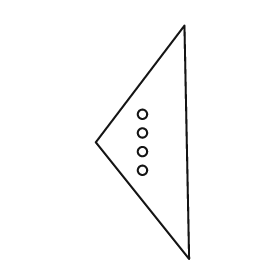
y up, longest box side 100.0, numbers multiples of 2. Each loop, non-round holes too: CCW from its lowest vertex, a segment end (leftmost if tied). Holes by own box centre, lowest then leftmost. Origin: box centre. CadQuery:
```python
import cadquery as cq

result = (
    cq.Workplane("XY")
    .moveTo(20.0, -50.0)
    .lineTo(18.0, 50.0)
    .lineTo(-20.0, 0.0)
    .close()
    .moveTo(0.0, -12.0)
    .circle(2.0)
    .moveTo(0.0, -4.0)
    .circle(2.0)
    .moveTo(0.0, 4.0)
    .circle(2.0)
    .moveTo(0.0, 12.0)
    .circle(2.0)
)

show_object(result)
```